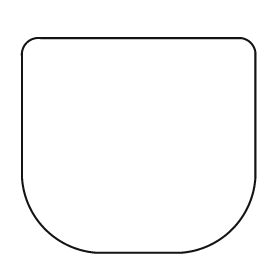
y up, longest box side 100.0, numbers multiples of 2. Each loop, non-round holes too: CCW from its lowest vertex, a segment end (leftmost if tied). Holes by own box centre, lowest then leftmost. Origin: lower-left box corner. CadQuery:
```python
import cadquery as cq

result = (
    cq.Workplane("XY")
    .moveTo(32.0, 0.0)
    .lineTo(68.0, 0.0)
    .threePointArc((90.0, 10.0), (100.0, 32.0))
    .lineTo(100.0, 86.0)
    .threePointArc((98.0, 90.0), (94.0, 92.0))
    .lineTo(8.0, 92.0)
    .threePointArc((2.0, 90.0), (0.0, 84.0))
    .lineTo(0.0, 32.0)
    .threePointArc((10.0, 10.0), (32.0, 0.0))
    .close()
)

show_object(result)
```